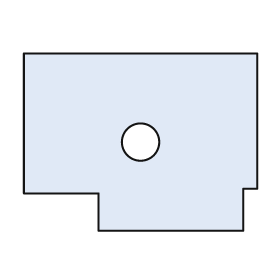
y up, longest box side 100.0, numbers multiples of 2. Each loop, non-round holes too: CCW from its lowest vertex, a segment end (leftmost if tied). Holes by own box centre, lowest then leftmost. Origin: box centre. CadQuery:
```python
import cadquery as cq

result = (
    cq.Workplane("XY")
    .moveTo(-18.0, -38.0)
    .lineTo(44.0, -38.0)
    .lineTo(44.0, -20.0)
    .lineTo(50.0, -20.0)
    .lineTo(50.0, 38.0)
    .lineTo(-50.0, 38.0)
    .lineTo(-50.0, -22.0)
    .lineTo(-18.0, -22.0)
    .close()
    .moveTo(0.0, 0.0)
    .circle(8.0)
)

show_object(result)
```